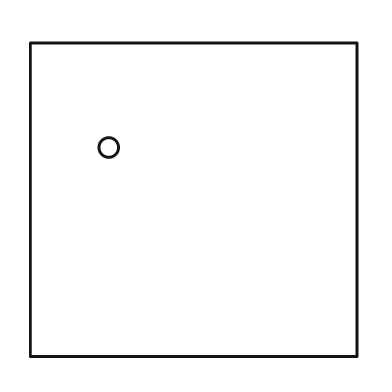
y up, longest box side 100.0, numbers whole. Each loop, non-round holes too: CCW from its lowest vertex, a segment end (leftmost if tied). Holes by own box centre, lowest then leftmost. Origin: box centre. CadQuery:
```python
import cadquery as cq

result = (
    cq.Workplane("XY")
    .moveTo(-50.0, -48.0)
    .lineTo(50.0, -48.0)
    .lineTo(50.0, 48.0)
    .lineTo(-50.0, 48.0)
    .close()
    .moveTo(-26.0, 16.0)
    .circle(3.0)
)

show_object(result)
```